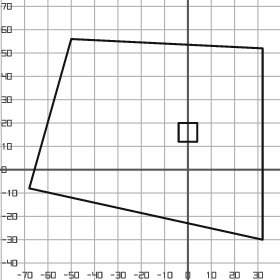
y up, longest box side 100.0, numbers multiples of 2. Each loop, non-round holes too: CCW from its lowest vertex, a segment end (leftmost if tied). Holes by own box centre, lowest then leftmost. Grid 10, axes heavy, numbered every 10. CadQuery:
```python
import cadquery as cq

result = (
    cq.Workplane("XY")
    .moveTo(32.0, -30.0)
    .lineTo(32.0, 52.0)
    .lineTo(-50.0, 56.0)
    .lineTo(-68.0, -8.0)
    .close()
    .moveTo(-4.0, 12.0)
    .lineTo(4.0, 12.0)
    .lineTo(4.0, 20.0)
    .lineTo(-4.0, 20.0)
    .close()
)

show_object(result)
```